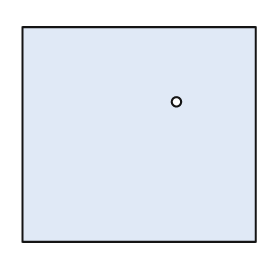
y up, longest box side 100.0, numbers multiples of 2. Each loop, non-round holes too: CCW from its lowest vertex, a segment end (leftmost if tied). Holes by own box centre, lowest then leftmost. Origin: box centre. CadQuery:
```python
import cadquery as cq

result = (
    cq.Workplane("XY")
    .moveTo(-50.0, -46.0)
    .lineTo(50.0, -46.0)
    .lineTo(50.0, 46.0)
    .lineTo(-50.0, 46.0)
    .close()
    .moveTo(16.0, 14.0)
    .circle(2.0)
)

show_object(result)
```